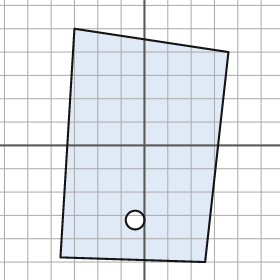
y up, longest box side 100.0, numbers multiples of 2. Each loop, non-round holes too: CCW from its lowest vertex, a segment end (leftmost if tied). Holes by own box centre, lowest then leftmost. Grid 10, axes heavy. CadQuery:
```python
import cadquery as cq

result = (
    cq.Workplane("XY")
    .moveTo(26.0, -50.0)
    .lineTo(36.0, 40.0)
    .lineTo(-30.0, 50.0)
    .lineTo(-36.0, -48.0)
    .close()
    .moveTo(-4.0, -32.0)
    .circle(4.0)
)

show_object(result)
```